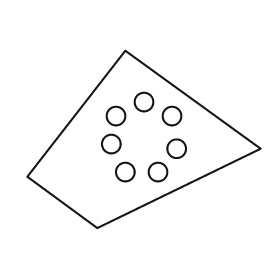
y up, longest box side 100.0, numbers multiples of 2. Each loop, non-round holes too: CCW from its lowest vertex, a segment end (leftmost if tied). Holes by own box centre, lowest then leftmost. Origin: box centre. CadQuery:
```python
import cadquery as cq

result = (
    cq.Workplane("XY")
    .moveTo(-20.0, -38.0)
    .lineTo(50.0, -4.0)
    .lineTo(-8.0, 38.0)
    .lineTo(-50.0, -16.0)
    .close()
    .moveTo(-8.0, -14.0)
    .circle(4.0)
    .moveTo(6.0, -14.0)
    .circle(4.0)
    .moveTo(14.0, -4.0)
    .circle(4.0)
    .moveTo(-14.0, -2.0)
    .circle(4.0)
    .moveTo(-12.0, 10.0)
    .circle(4.0)
    .moveTo(12.0, 10.0)
    .circle(4.0)
    .moveTo(0.0, 16.0)
    .circle(4.0)
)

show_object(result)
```